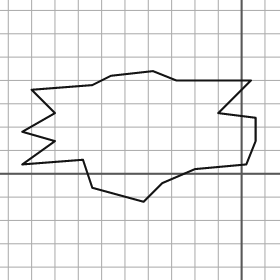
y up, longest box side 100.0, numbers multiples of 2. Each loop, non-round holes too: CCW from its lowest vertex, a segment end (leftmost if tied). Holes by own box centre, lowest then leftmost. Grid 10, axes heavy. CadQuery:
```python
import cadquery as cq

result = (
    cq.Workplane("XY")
    .moveTo(-42.0, -12.0)
    .lineTo(-34.0, -4.0)
    .lineTo(-20.0, 2.0)
    .lineTo(2.0, 4.0)
    .lineTo(6.0, 14.0)
    .lineTo(6.0, 24.0)
    .lineTo(-10.0, 26.0)
    .lineTo(4.0, 40.0)
    .lineTo(-28.0, 40.0)
    .lineTo(-38.0, 44.0)
    .lineTo(-56.0, 42.0)
    .lineTo(-64.0, 38.0)
    .lineTo(-90.0, 36.0)
    .lineTo(-80.0, 26.0)
    .lineTo(-94.0, 18.0)
    .lineTo(-80.0, 14.0)
    .lineTo(-94.0, 4.0)
    .lineTo(-68.0, 6.0)
    .lineTo(-64.0, -6.0)
    .close()
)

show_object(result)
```